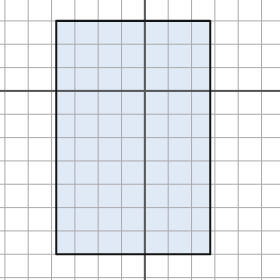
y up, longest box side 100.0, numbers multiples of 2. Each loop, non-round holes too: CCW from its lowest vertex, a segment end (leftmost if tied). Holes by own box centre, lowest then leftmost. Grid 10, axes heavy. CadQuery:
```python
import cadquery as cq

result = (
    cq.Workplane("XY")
    .moveTo(-38.0, -70.0)
    .lineTo(28.0, -70.0)
    .lineTo(28.0, 30.0)
    .lineTo(-38.0, 30.0)
    .close()
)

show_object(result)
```